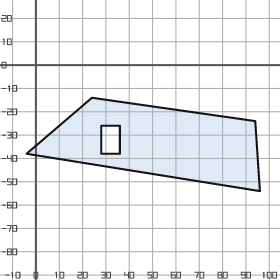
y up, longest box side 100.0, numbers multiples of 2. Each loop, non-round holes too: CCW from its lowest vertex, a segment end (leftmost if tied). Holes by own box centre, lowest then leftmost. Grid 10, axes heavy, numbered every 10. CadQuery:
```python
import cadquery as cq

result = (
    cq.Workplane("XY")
    .moveTo(96.0, -54.0)
    .lineTo(94.0, -24.0)
    .lineTo(24.0, -14.0)
    .lineTo(-4.0, -38.0)
    .close()
    .moveTo(28.0, -38.0)
    .lineTo(36.0, -38.0)
    .lineTo(36.0, -26.0)
    .lineTo(28.0, -26.0)
    .close()
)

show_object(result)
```